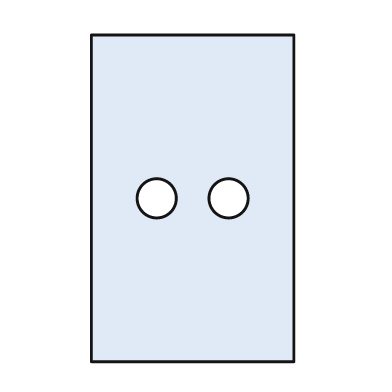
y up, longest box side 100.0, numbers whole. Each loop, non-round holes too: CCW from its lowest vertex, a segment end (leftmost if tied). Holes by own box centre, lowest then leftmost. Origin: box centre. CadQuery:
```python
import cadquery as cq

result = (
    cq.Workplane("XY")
    .moveTo(-31.0, -50.0)
    .lineTo(31.0, -50.0)
    .lineTo(31.0, 50.0)
    .lineTo(-31.0, 50.0)
    .close()
    .moveTo(-11.0, 0.0)
    .circle(6.0)
    .moveTo(11.0, 0.0)
    .circle(6.0)
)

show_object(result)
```